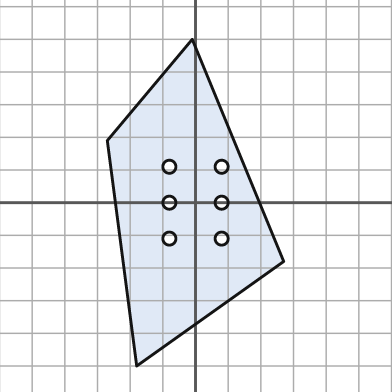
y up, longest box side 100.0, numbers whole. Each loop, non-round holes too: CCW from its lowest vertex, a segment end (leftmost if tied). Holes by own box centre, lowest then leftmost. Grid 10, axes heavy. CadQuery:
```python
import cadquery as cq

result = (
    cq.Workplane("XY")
    .moveTo(-18.0, -50.0)
    .lineTo(27.0, -18.0)
    .lineTo(-1.0, 50.0)
    .lineTo(-27.0, 19.0)
    .close()
    .moveTo(-8.0, -11.0)
    .circle(2.0)
    .moveTo(8.0, -11.0)
    .circle(2.0)
    .moveTo(-8.0, 0.0)
    .circle(2.0)
    .moveTo(8.0, 0.0)
    .circle(2.0)
    .moveTo(-8.0, 11.0)
    .circle(2.0)
    .moveTo(8.0, 11.0)
    .circle(2.0)
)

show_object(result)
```